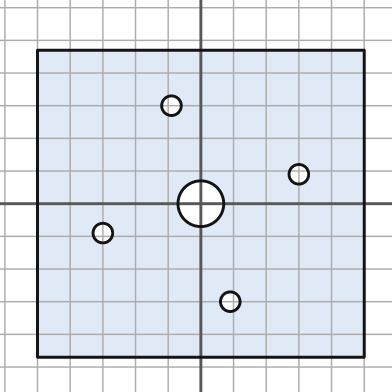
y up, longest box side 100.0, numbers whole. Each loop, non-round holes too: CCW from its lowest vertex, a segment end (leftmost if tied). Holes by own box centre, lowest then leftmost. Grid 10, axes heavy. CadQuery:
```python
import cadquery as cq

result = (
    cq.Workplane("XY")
    .moveTo(-50.0, -47.0)
    .lineTo(50.0, -47.0)
    .lineTo(50.0, 47.0)
    .lineTo(-50.0, 47.0)
    .close()
    .moveTo(9.0, -30.0)
    .circle(3.0)
    .moveTo(-30.0, -9.0)
    .circle(3.0)
    .moveTo(0.0, 0.0)
    .circle(7.0)
    .moveTo(30.0, 9.0)
    .circle(3.0)
    .moveTo(-9.0, 30.0)
    .circle(3.0)
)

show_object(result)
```